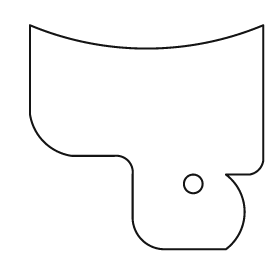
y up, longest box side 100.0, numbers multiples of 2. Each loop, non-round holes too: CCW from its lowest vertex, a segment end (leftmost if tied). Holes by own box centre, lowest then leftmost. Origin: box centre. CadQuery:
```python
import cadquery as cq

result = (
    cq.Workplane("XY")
    .moveTo(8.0, -48.0)
    .lineTo(34.0, -48.0)
    .threePointArc((42.0, -32.0), (34.0, -16.0))
    .lineTo(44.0, -16.0)
    .threePointArc((48.0, -14.0), (50.0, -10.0))
    .lineTo(50.0, 48.0)
    .threePointArc((0.0, 38.0), (-50.0, 48.0))
    .lineTo(-50.0, 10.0)
    .threePointArc((-44.0, -2.0), (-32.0, -8.0))
    .lineTo(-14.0, -8.0)
    .threePointArc((-8.0, -10.0), (-6.0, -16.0))
    .lineTo(-6.0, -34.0)
    .threePointArc((-2.0, -44.0), (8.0, -48.0))
    .close()
    .moveTo(20.0, -20.0)
    .circle(4.0)
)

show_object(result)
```